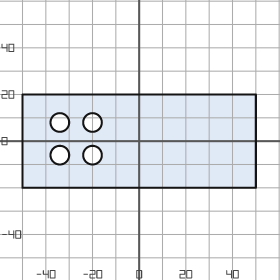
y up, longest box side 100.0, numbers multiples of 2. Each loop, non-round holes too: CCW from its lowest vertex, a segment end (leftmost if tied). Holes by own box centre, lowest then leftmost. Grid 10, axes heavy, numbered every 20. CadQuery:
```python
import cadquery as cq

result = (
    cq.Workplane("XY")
    .moveTo(-50.0, -20.0)
    .lineTo(50.0, -20.0)
    .lineTo(50.0, 20.0)
    .lineTo(-50.0, 20.0)
    .close()
    .moveTo(-34.0, -6.0)
    .circle(4.0)
    .moveTo(-20.0, -6.0)
    .circle(4.0)
    .moveTo(-34.0, 8.0)
    .circle(4.0)
    .moveTo(-20.0, 8.0)
    .circle(4.0)
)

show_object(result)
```